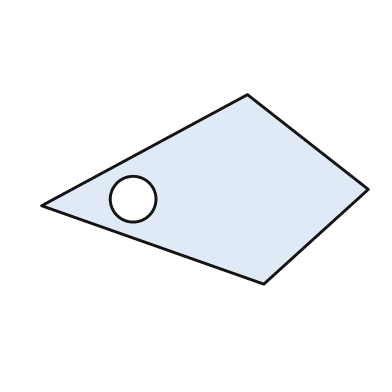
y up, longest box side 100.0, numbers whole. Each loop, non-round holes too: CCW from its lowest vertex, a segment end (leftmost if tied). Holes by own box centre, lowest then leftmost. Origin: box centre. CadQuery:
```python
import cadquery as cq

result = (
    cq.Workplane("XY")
    .moveTo(18.0, -29.0)
    .lineTo(50.0, 0.0)
    .lineTo(13.0, 29.0)
    .lineTo(-50.0, -5.0)
    .close()
    .moveTo(-22.0, -3.0)
    .circle(7.0)
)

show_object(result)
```